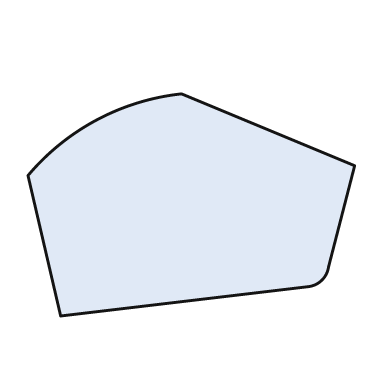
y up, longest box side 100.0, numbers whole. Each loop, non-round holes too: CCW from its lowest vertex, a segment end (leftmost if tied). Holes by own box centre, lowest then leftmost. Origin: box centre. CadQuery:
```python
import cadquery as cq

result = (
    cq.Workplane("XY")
    .moveTo(-40.0, -34.0)
    .lineTo(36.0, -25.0)
    .threePointArc((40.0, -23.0), (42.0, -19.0))
    .lineTo(50.0, 12.0)
    .lineTo(-3.0, 34.0)
    .threePointArc((-29.0, 26.0), (-50.0, 9.0))
    .close()
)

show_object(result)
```